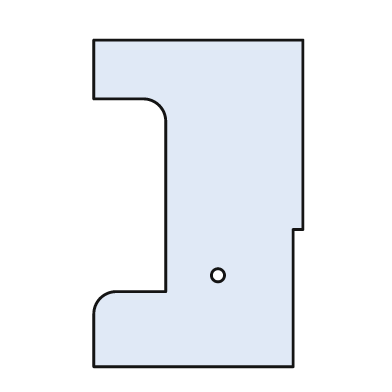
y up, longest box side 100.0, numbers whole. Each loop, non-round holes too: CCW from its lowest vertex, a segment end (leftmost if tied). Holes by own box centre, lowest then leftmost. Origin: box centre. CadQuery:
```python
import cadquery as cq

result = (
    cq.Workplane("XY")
    .moveTo(-32.0, -50.0)
    .lineTo(29.0, -50.0)
    .lineTo(29.0, -8.0)
    .lineTo(32.0, -8.0)
    .lineTo(32.0, 50.0)
    .lineTo(-32.0, 50.0)
    .lineTo(-32.0, 32.0)
    .lineTo(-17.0, 32.0)
    .threePointArc((-12.0, 30.0), (-10.0, 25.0))
    .lineTo(-10.0, -27.0)
    .lineTo(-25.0, -27.0)
    .threePointArc((-30.0, -29.0), (-32.0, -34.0))
    .close()
    .moveTo(6.0, -22.0)
    .circle(2.0)
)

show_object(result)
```